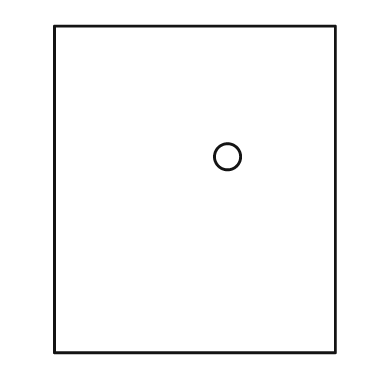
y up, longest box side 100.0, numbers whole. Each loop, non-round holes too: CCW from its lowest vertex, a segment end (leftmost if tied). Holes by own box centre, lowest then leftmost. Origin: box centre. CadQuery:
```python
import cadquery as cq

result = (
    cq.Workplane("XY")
    .moveTo(-43.0, -50.0)
    .lineTo(43.0, -50.0)
    .lineTo(43.0, 50.0)
    .lineTo(-43.0, 50.0)
    .close()
    .moveTo(10.0, 10.0)
    .circle(4.0)
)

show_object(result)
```